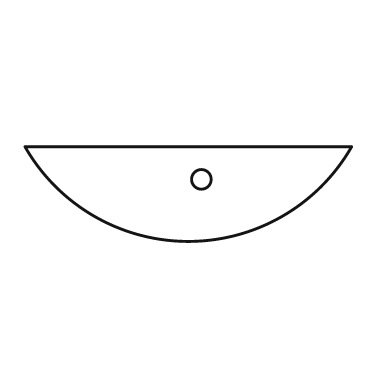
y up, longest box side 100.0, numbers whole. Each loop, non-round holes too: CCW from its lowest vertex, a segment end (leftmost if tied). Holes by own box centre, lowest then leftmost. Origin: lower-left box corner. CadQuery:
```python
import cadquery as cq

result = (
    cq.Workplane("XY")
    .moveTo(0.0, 29.0)
    .threePointArc((50.0, 0.0), (100.0, 29.0))
    .close()
    .moveTo(54.0, 19.0)
    .circle(3.0)
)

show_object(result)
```